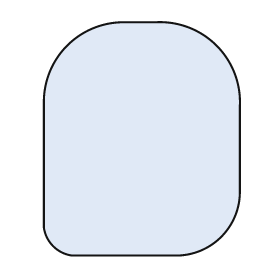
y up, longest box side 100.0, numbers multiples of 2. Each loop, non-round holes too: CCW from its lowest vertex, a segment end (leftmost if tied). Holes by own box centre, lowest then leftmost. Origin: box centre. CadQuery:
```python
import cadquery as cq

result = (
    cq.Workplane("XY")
    .moveTo(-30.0, -50.0)
    .lineTo(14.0, -50.0)
    .threePointArc((34.0, -42.0), (42.0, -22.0))
    .lineTo(42.0, 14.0)
    .threePointArc((32.0, 40.0), (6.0, 50.0))
    .lineTo(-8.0, 50.0)
    .threePointArc((-32.0, 40.0), (-42.0, 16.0))
    .lineTo(-42.0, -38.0)
    .threePointArc((-38.0, -46.0), (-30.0, -50.0))
    .close()
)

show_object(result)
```